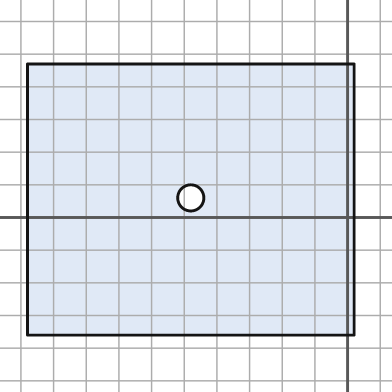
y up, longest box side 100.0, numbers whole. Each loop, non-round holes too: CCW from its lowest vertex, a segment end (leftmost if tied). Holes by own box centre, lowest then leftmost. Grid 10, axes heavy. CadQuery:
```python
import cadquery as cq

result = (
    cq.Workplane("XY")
    .moveTo(-98.0, -36.0)
    .lineTo(2.0, -36.0)
    .lineTo(2.0, 47.0)
    .lineTo(-98.0, 47.0)
    .close()
    .moveTo(-48.0, 6.0)
    .circle(4.0)
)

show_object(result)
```